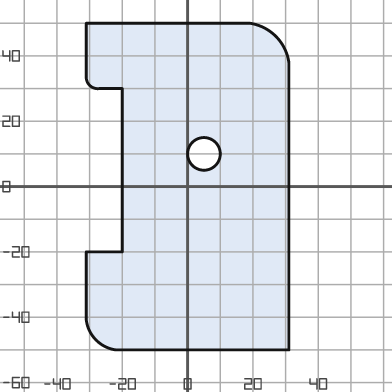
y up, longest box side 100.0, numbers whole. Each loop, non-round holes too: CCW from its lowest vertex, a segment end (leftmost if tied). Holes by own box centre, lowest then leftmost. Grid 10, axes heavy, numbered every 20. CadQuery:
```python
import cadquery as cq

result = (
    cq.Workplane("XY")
    .moveTo(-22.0, -50.0)
    .lineTo(31.0, -50.0)
    .lineTo(31.0, 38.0)
    .threePointArc((27.0, 46.0), (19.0, 50.0))
    .lineTo(-31.0, 50.0)
    .lineTo(-31.0, 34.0)
    .threePointArc((-30.0, 31.0), (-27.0, 30.0))
    .lineTo(-20.0, 30.0)
    .lineTo(-20.0, -20.0)
    .lineTo(-31.0, -20.0)
    .lineTo(-31.0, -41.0)
    .threePointArc((-28.0, -47.0), (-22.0, -50.0))
    .close()
    .moveTo(5.0, 10.0)
    .circle(5.0)
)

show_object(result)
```